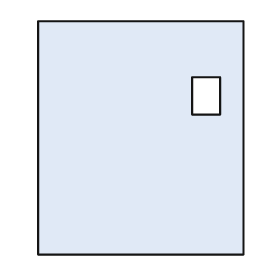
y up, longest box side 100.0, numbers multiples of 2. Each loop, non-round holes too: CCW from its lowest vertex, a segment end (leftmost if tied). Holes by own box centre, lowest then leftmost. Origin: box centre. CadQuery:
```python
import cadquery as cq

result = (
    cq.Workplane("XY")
    .moveTo(-44.0, -50.0)
    .lineTo(44.0, -50.0)
    .lineTo(44.0, 50.0)
    .lineTo(-44.0, 50.0)
    .close()
    .moveTo(22.0, 10.0)
    .lineTo(34.0, 10.0)
    .lineTo(34.0, 26.0)
    .lineTo(22.0, 26.0)
    .close()
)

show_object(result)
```